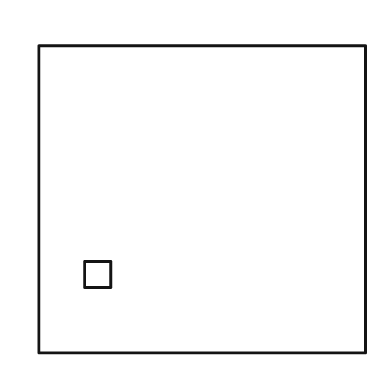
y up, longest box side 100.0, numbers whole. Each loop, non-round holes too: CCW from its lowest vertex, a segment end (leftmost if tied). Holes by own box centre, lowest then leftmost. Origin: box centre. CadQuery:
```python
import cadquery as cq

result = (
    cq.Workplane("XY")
    .moveTo(-50.0, -47.0)
    .lineTo(50.0, -47.0)
    .lineTo(50.0, 47.0)
    .lineTo(-50.0, 47.0)
    .close()
    .moveTo(-36.0, -27.0)
    .lineTo(-28.0, -27.0)
    .lineTo(-28.0, -19.0)
    .lineTo(-36.0, -19.0)
    .close()
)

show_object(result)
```